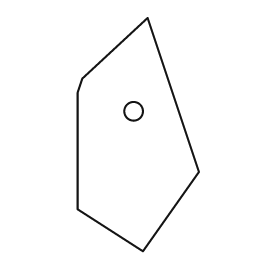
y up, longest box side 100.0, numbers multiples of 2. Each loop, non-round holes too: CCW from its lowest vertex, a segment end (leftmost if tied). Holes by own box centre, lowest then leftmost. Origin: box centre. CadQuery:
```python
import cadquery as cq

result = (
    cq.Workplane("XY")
    .moveTo(2.0, -50.0)
    .lineTo(26.0, -16.0)
    .lineTo(4.0, 50.0)
    .lineTo(-24.0, 24.0)
    .lineTo(-26.0, 18.0)
    .lineTo(-26.0, -32.0)
    .close()
    .moveTo(-2.0, 10.0)
    .circle(4.0)
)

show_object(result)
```